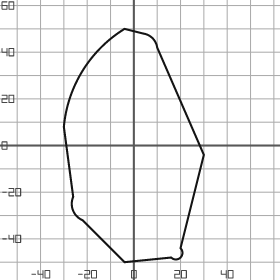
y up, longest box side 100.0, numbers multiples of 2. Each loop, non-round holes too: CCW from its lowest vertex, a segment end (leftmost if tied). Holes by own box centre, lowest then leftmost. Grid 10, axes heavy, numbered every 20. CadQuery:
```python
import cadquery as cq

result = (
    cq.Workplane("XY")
    .moveTo(-4.0, -50.0)
    .lineTo(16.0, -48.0)
    .threePointArc((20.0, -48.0), (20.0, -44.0))
    .lineTo(30.0, -4.0)
    .lineTo(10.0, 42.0)
    .threePointArc((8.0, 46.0), (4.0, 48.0))
    .lineTo(-4.0, 50.0)
    .threePointArc((-22.0, 32.0), (-30.0, 8.0))
    .lineTo(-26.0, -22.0)
    .threePointArc((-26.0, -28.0), (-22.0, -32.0))
    .close()
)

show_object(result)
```